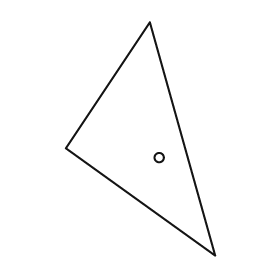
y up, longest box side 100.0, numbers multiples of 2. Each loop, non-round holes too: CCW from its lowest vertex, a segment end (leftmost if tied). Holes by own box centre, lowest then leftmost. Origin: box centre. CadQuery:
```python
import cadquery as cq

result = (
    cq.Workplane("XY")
    .moveTo(32.0, -50.0)
    .lineTo(4.0, 50.0)
    .lineTo(-32.0, -4.0)
    .close()
    .moveTo(8.0, -8.0)
    .circle(2.0)
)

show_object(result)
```